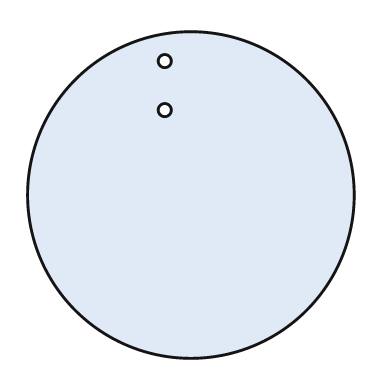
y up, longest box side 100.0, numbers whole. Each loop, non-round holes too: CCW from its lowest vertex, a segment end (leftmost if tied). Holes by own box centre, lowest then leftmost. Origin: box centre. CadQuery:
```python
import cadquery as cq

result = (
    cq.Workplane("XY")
    .moveTo(0.0, 0.0)
    .circle(50.0)
    .moveTo(-8.0, 26.0)
    .circle(2.0)
    .moveTo(-8.0, 41.0)
    .circle(2.0)
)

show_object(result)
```